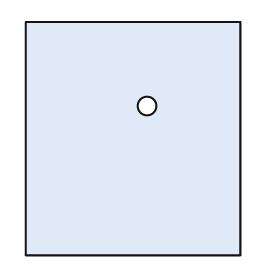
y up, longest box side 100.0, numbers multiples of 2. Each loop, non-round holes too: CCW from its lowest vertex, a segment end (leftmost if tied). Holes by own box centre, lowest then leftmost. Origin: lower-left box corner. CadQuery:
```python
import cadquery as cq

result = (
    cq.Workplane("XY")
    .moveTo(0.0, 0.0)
    .lineTo(92.0, 0.0)
    .lineTo(92.0, 100.0)
    .lineTo(0.0, 100.0)
    .close()
    .moveTo(52.0, 64.0)
    .circle(4.0)
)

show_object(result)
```